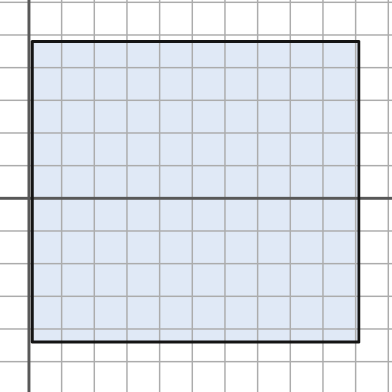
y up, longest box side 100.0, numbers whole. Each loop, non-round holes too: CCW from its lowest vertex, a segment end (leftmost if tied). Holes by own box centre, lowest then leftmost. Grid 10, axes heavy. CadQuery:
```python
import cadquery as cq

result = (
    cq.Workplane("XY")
    .moveTo(1.0, -44.0)
    .lineTo(101.0, -44.0)
    .lineTo(101.0, 48.0)
    .lineTo(1.0, 48.0)
    .close()
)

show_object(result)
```